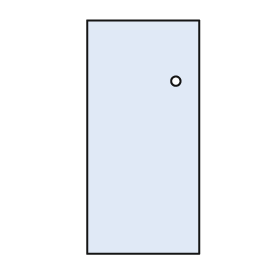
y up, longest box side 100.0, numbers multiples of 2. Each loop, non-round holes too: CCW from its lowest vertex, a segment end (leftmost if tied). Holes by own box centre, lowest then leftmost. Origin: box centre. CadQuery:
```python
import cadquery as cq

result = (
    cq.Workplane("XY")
    .moveTo(-24.0, -50.0)
    .lineTo(24.0, -50.0)
    .lineTo(24.0, 50.0)
    .lineTo(-24.0, 50.0)
    .close()
    .moveTo(14.0, 24.0)
    .circle(2.0)
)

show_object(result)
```